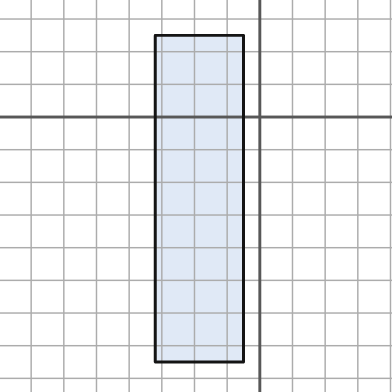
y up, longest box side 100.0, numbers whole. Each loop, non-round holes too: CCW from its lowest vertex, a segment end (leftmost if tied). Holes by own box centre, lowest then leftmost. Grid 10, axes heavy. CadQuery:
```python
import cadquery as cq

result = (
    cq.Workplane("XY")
    .moveTo(-32.0, -75.0)
    .lineTo(-5.0, -75.0)
    .lineTo(-5.0, 25.0)
    .lineTo(-32.0, 25.0)
    .close()
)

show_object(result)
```